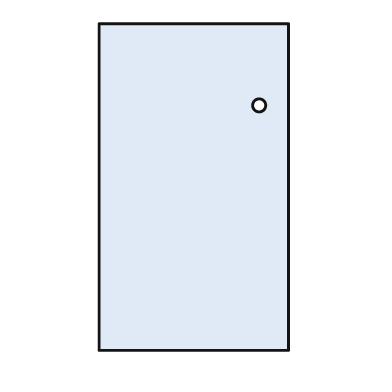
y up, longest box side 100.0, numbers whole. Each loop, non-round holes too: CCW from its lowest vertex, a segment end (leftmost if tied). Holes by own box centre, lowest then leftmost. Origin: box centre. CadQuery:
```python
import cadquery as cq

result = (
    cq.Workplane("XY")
    .moveTo(-29.0, -50.0)
    .lineTo(29.0, -50.0)
    .lineTo(29.0, 50.0)
    .lineTo(-29.0, 50.0)
    .close()
    .moveTo(20.0, 25.0)
    .circle(2.0)
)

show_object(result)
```